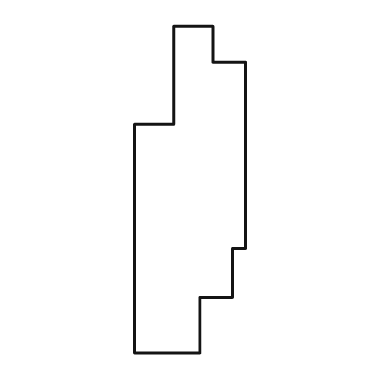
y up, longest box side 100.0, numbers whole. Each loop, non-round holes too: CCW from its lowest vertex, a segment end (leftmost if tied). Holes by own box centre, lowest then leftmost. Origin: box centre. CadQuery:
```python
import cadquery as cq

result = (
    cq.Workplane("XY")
    .moveTo(-17.0, -50.0)
    .lineTo(3.0, -50.0)
    .lineTo(3.0, -33.0)
    .lineTo(13.0, -33.0)
    .lineTo(13.0, -18.0)
    .lineTo(17.0, -18.0)
    .lineTo(17.0, 39.0)
    .lineTo(7.0, 39.0)
    .lineTo(7.0, 50.0)
    .lineTo(-5.0, 50.0)
    .lineTo(-5.0, 20.0)
    .lineTo(-17.0, 20.0)
    .close()
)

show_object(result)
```